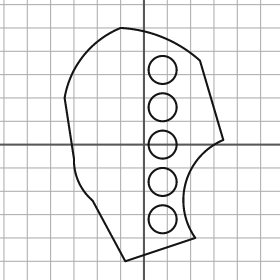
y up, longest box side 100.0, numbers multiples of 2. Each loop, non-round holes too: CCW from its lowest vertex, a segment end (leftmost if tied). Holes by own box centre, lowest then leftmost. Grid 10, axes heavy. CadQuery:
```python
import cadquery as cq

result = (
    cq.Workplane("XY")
    .moveTo(-8.0, -50.0)
    .lineTo(22.0, -40.0)
    .threePointArc((18.0, -16.0), (34.0, 2.0))
    .lineTo(24.0, 36.0)
    .threePointArc((8.0, 46.0), (-10.0, 50.0))
    .threePointArc((-26.0, 38.0), (-34.0, 20.0))
    .lineTo(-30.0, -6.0)
    .threePointArc((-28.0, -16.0), (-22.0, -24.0))
    .close()
    .moveTo(8.0, -32.0)
    .circle(6.0)
    .moveTo(8.0, -16.0)
    .circle(6.0)
    .moveTo(8.0, 0.0)
    .circle(6.0)
    .moveTo(8.0, 16.0)
    .circle(6.0)
    .moveTo(8.0, 32.0)
    .circle(6.0)
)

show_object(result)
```